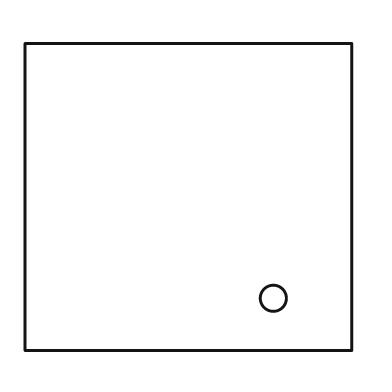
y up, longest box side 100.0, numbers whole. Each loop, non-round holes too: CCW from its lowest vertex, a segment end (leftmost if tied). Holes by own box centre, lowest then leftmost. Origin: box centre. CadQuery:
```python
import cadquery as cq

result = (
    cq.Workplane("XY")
    .moveTo(-50.0, -47.0)
    .lineTo(50.0, -47.0)
    .lineTo(50.0, 47.0)
    .lineTo(-50.0, 47.0)
    .close()
    .moveTo(26.0, -31.0)
    .circle(4.0)
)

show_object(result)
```